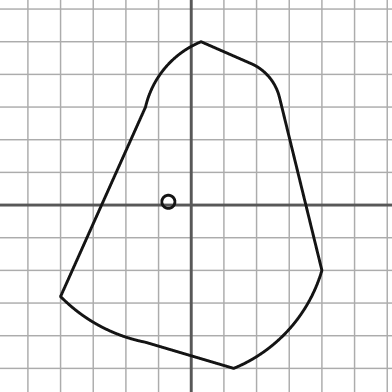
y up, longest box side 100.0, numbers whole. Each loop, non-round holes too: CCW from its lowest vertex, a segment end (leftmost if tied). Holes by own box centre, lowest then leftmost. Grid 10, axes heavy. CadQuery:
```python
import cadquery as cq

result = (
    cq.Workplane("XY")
    .moveTo(13.0, -50.0)
    .threePointArc((30.0, -38.0), (40.0, -20.0))
    .lineTo(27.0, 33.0)
    .threePointArc((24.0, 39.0), (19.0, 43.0))
    .lineTo(3.0, 50.0)
    .threePointArc((-8.0, 42.0), (-14.0, 30.0))
    .lineTo(-40.0, -28.0)
    .threePointArc((-28.0, -37.0), (-14.0, -42.0))
    .close()
    .moveTo(-7.0, 1.0)
    .circle(2.0)
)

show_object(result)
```